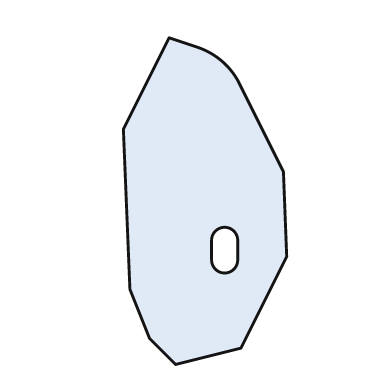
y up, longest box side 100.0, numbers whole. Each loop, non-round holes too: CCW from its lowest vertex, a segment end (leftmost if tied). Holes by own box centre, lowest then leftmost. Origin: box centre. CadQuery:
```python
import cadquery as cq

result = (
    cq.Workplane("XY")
    .moveTo(-9.0, -50.0)
    .lineTo(11.0, -45.0)
    .lineTo(25.0, -17.0)
    .lineTo(24.0, 9.0)
    .lineTo(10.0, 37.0)
    .threePointArc((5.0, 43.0), (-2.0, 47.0))
    .lineTo(-11.0, 50.0)
    .lineTo(-25.0, 22.0)
    .lineTo(-23.0, -27.0)
    .lineTo(-17.0, -42.0)
    .close()
    .moveTo(2.0, -18.0)
    .threePointArc((6.0, -22.0), (10.0, -18.0))
    .lineTo(10.0, -12.0)
    .threePointArc((6.0, -8.0), (2.0, -12.0))
    .close()
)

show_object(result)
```